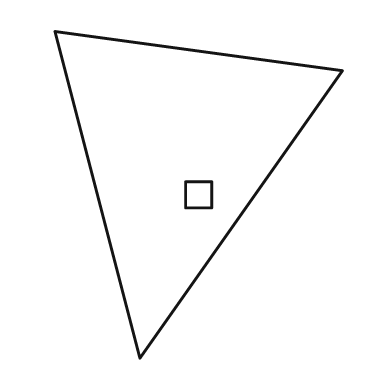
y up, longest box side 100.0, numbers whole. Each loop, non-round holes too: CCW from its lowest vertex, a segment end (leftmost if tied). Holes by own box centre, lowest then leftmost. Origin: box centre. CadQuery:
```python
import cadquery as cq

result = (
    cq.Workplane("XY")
    .moveTo(-18.0, -50.0)
    .lineTo(44.0, 38.0)
    .lineTo(-44.0, 50.0)
    .close()
    .moveTo(-4.0, -4.0)
    .lineTo(4.0, -4.0)
    .lineTo(4.0, 4.0)
    .lineTo(-4.0, 4.0)
    .close()
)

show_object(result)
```